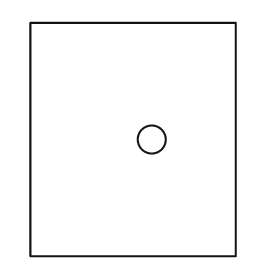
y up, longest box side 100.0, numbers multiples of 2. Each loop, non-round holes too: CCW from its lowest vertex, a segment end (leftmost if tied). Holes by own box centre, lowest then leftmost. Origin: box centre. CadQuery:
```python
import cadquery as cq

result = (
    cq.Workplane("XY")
    .moveTo(-44.0, -50.0)
    .lineTo(44.0, -50.0)
    .lineTo(44.0, 50.0)
    .lineTo(-44.0, 50.0)
    .close()
    .moveTo(8.0, 0.0)
    .circle(6.0)
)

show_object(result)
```